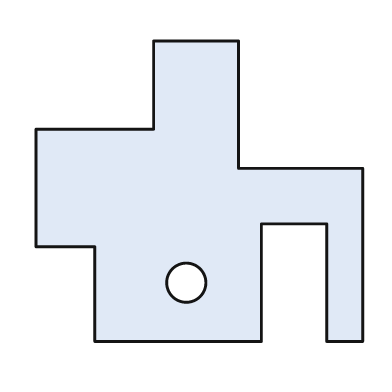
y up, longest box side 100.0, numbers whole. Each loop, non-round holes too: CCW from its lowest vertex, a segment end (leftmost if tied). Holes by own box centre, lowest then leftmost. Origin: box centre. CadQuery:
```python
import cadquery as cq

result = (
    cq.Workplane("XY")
    .moveTo(-32.0, -46.0)
    .lineTo(19.0, -46.0)
    .lineTo(19.0, -10.0)
    .lineTo(39.0, -10.0)
    .lineTo(39.0, -46.0)
    .lineTo(50.0, -46.0)
    .lineTo(50.0, 7.0)
    .lineTo(12.0, 7.0)
    .lineTo(12.0, 46.0)
    .lineTo(-14.0, 46.0)
    .lineTo(-14.0, 19.0)
    .lineTo(-50.0, 19.0)
    .lineTo(-50.0, -17.0)
    .lineTo(-32.0, -17.0)
    .close()
    .moveTo(-4.0, -28.0)
    .circle(6.0)
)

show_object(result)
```